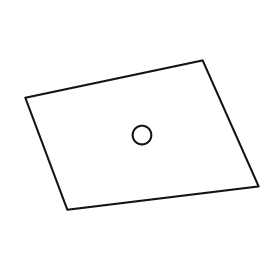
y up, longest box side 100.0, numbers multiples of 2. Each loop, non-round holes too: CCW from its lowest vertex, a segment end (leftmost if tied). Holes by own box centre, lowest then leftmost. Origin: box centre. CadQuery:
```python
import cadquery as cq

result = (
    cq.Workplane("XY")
    .moveTo(-32.0, -32.0)
    .lineTo(50.0, -22.0)
    .lineTo(26.0, 32.0)
    .lineTo(-50.0, 16.0)
    .close()
    .moveTo(0.0, 0.0)
    .circle(4.0)
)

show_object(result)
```